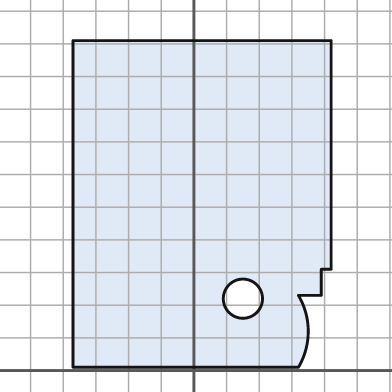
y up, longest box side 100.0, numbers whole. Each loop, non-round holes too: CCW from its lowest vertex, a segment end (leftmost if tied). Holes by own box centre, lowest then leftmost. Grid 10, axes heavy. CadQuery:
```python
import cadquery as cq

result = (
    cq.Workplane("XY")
    .moveTo(-37.0, 1.0)
    .lineTo(32.0, 1.0)
    .threePointArc((35.0, 12.0), (32.0, 23.0))
    .lineTo(39.0, 23.0)
    .lineTo(39.0, 31.0)
    .lineTo(42.0, 31.0)
    .lineTo(42.0, 101.0)
    .lineTo(-37.0, 101.0)
    .close()
    .moveTo(15.0, 22.0)
    .circle(6.0)
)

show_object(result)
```